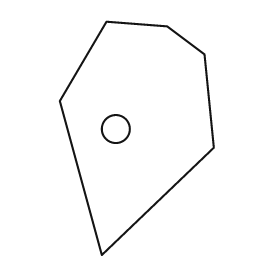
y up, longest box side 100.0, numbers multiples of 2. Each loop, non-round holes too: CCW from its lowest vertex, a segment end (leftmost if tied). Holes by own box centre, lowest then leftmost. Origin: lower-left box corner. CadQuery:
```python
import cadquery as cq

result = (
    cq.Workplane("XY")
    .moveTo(18.0, 0.0)
    .lineTo(66.0, 46.0)
    .lineTo(62.0, 86.0)
    .lineTo(46.0, 98.0)
    .lineTo(20.0, 100.0)
    .lineTo(0.0, 66.0)
    .close()
    .moveTo(24.0, 54.0)
    .circle(6.0)
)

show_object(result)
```